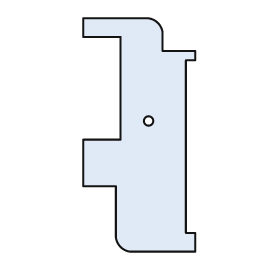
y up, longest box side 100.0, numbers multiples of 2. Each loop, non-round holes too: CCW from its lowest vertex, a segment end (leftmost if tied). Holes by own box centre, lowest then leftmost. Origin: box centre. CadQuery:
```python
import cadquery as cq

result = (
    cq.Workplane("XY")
    .moveTo(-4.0, -50.0)
    .lineTo(24.0, -50.0)
    .lineTo(24.0, -42.0)
    .lineTo(20.0, -42.0)
    .lineTo(20.0, 32.0)
    .lineTo(24.0, 32.0)
    .lineTo(24.0, 36.0)
    .lineTo(10.0, 36.0)
    .lineTo(10.0, 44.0)
    .threePointArc((8.0, 48.0), (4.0, 50.0))
    .lineTo(-24.0, 50.0)
    .lineTo(-24.0, 42.0)
    .lineTo(-8.0, 42.0)
    .lineTo(-8.0, -2.0)
    .lineTo(-24.0, -2.0)
    .lineTo(-24.0, -22.0)
    .lineTo(-10.0, -22.0)
    .lineTo(-10.0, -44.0)
    .threePointArc((-8.0, -48.0), (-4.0, -50.0))
    .close()
    .moveTo(4.0, 6.0)
    .circle(2.0)
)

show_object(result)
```